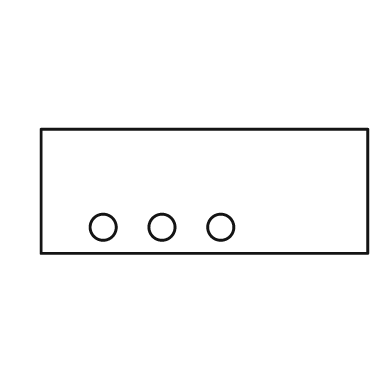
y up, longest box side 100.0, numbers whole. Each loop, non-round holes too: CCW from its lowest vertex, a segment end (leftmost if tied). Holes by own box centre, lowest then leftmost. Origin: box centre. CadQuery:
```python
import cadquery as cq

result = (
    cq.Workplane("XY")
    .moveTo(-50.0, -19.0)
    .lineTo(50.0, -19.0)
    .lineTo(50.0, 19.0)
    .lineTo(-50.0, 19.0)
    .close()
    .moveTo(-31.0, -11.0)
    .circle(4.0)
    .moveTo(-13.0, -11.0)
    .circle(4.0)
    .moveTo(5.0, -11.0)
    .circle(4.0)
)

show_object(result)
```